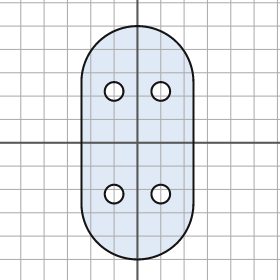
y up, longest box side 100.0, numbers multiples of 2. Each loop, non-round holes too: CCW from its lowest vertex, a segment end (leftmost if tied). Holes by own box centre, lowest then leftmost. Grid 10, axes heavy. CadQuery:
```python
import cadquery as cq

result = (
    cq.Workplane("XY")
    .moveTo(-24.0, -26.0)
    .threePointArc((0.0, -50.0), (24.0, -26.0))
    .lineTo(24.0, 26.0)
    .threePointArc((0.0, 50.0), (-24.0, 26.0))
    .close()
    .moveTo(-10.0, -22.0)
    .circle(4.0)
    .moveTo(10.0, -22.0)
    .circle(4.0)
    .moveTo(-10.0, 22.0)
    .circle(4.0)
    .moveTo(10.0, 22.0)
    .circle(4.0)
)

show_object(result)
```